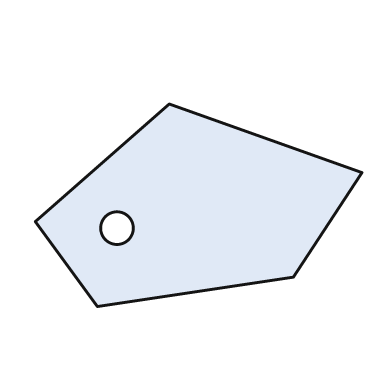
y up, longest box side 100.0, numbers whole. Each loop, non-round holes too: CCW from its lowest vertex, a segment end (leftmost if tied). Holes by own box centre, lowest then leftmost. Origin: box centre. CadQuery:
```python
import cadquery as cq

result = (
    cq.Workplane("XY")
    .moveTo(-31.0, -31.0)
    .lineTo(29.0, -22.0)
    .lineTo(50.0, 10.0)
    .lineTo(-9.0, 31.0)
    .lineTo(-50.0, -5.0)
    .close()
    .moveTo(-25.0, -7.0)
    .circle(5.0)
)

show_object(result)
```